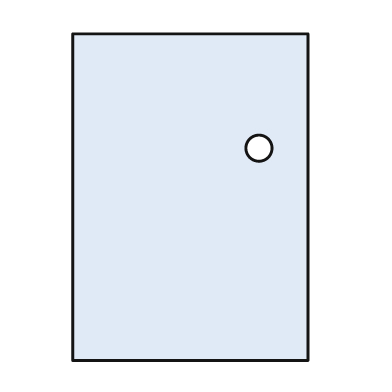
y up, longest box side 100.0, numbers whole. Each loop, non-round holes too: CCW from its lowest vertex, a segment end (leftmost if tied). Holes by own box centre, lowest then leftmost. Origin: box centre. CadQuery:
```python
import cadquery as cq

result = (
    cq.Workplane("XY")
    .moveTo(-36.0, -50.0)
    .lineTo(36.0, -50.0)
    .lineTo(36.0, 50.0)
    .lineTo(-36.0, 50.0)
    .close()
    .moveTo(21.0, 15.0)
    .circle(4.0)
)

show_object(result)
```